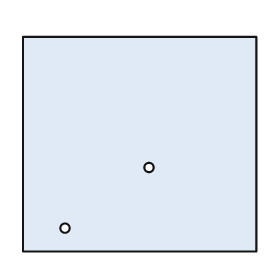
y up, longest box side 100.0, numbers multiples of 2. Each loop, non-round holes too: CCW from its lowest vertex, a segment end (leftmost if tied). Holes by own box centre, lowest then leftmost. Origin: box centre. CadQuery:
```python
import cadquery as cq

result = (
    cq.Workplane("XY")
    .moveTo(-50.0, -46.0)
    .lineTo(50.0, -46.0)
    .lineTo(50.0, 46.0)
    .lineTo(-50.0, 46.0)
    .close()
    .moveTo(-32.0, -36.0)
    .circle(2.0)
    .moveTo(4.0, -10.0)
    .circle(2.0)
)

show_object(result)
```